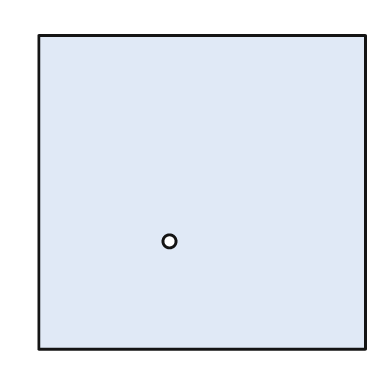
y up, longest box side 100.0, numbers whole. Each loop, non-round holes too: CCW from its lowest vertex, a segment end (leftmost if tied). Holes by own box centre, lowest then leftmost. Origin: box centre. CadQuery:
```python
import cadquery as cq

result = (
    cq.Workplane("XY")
    .moveTo(-50.0, -48.0)
    .lineTo(50.0, -48.0)
    .lineTo(50.0, 48.0)
    .lineTo(-50.0, 48.0)
    .close()
    .moveTo(-10.0, -15.0)
    .circle(2.0)
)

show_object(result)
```